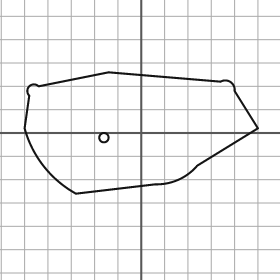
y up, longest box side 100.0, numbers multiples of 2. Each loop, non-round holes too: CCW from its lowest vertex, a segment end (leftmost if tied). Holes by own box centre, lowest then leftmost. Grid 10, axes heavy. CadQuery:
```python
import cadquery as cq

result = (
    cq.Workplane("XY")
    .moveTo(-28.0, -26.0)
    .lineTo(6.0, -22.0)
    .threePointArc((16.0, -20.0), (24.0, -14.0))
    .lineTo(50.0, 2.0)
    .lineTo(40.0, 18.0)
    .threePointArc((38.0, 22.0), (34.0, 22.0))
    .lineTo(-14.0, 26.0)
    .lineTo(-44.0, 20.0)
    .threePointArc((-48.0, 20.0), (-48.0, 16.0))
    .lineTo(-50.0, 2.0)
    .threePointArc((-42.0, -14.0), (-28.0, -26.0))
    .close()
    .moveTo(-16.0, -2.0)
    .circle(2.0)
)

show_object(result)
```